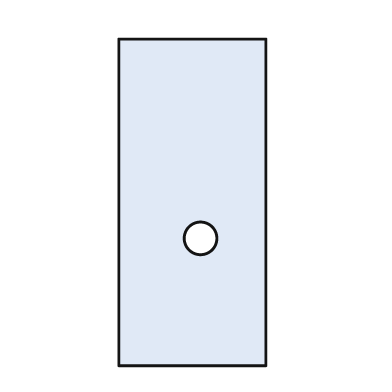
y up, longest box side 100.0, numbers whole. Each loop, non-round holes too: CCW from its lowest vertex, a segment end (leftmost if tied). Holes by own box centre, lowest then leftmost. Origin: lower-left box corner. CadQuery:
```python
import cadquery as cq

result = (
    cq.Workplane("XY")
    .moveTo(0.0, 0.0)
    .lineTo(45.0, 0.0)
    .lineTo(45.0, 100.0)
    .lineTo(0.0, 100.0)
    .close()
    .moveTo(25.0, 39.0)
    .circle(5.0)
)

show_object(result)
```